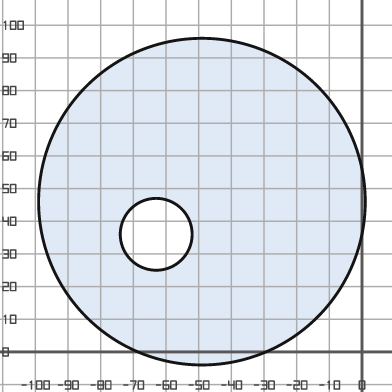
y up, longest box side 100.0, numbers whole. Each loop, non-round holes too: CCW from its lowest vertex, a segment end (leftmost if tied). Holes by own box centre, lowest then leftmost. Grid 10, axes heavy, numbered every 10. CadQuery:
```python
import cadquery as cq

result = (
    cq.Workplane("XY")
    .moveTo(-49.0, 46.0)
    .circle(50.0)
    .moveTo(-63.0, 36.0)
    .circle(11.0)
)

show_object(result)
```